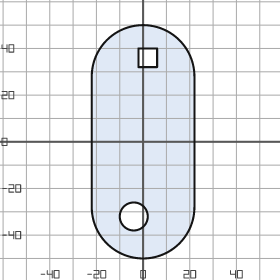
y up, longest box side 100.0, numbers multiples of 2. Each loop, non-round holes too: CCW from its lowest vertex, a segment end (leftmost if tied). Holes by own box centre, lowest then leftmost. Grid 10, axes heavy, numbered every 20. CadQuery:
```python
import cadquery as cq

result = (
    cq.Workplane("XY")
    .moveTo(-22.0, -28.0)
    .threePointArc((0.0, -50.0), (22.0, -28.0))
    .lineTo(22.0, 28.0)
    .threePointArc((0.0, 50.0), (-22.0, 28.0))
    .close()
    .moveTo(-4.0, -32.0)
    .circle(6.0)
    .moveTo(-2.0, 32.0)
    .lineTo(6.0, 32.0)
    .lineTo(6.0, 40.0)
    .lineTo(-2.0, 40.0)
    .close()
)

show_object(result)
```